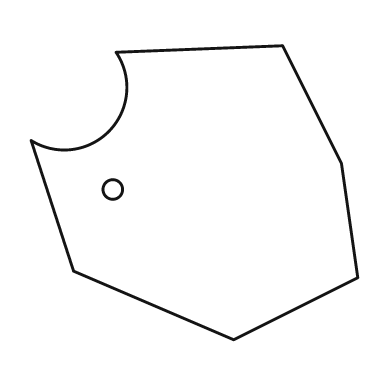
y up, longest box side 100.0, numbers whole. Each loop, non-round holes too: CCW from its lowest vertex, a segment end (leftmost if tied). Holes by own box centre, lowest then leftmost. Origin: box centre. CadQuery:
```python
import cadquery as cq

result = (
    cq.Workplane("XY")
    .moveTo(12.0, -45.0)
    .lineTo(50.0, -26.0)
    .lineTo(45.0, 9.0)
    .lineTo(27.0, 45.0)
    .lineTo(-24.0, 43.0)
    .threePointArc((-26.0, 19.0), (-50.0, 16.0))
    .lineTo(-37.0, -24.0)
    .close()
    .moveTo(-25.0, 1.0)
    .circle(3.0)
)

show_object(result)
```